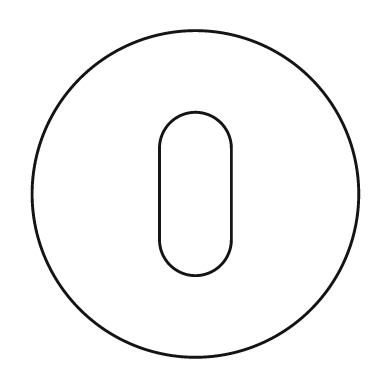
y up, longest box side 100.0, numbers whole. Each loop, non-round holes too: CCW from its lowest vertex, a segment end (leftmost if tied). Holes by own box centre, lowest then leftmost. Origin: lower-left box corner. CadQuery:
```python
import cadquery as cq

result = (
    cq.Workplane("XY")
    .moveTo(50.0, 50.0)
    .circle(50.0)
    .moveTo(39.0, 36.0)
    .threePointArc((50.0, 25.0), (61.0, 36.0))
    .lineTo(61.0, 64.0)
    .threePointArc((50.0, 75.0), (39.0, 64.0))
    .close()
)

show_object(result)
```